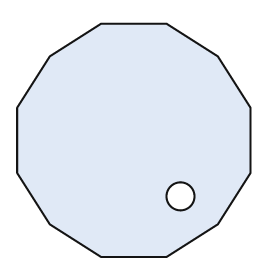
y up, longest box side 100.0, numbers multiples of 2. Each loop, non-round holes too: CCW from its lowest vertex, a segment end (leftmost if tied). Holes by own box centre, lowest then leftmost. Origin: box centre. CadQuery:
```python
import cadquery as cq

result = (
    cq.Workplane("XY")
    .moveTo(-14.0, -50.0)
    .lineTo(14.0, -50.0)
    .lineTo(36.0, -36.0)
    .lineTo(50.0, -14.0)
    .lineTo(50.0, 14.0)
    .lineTo(36.0, 36.0)
    .lineTo(14.0, 50.0)
    .lineTo(-14.0, 50.0)
    .lineTo(-36.0, 36.0)
    .lineTo(-50.0, 14.0)
    .lineTo(-50.0, -14.0)
    .lineTo(-36.0, -36.0)
    .close()
    .moveTo(20.0, -24.0)
    .circle(6.0)
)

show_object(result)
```